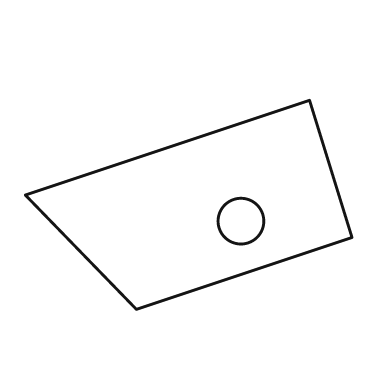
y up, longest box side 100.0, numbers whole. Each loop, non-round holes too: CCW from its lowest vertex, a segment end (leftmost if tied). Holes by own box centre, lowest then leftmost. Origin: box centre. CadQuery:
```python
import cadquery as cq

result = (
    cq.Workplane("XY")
    .moveTo(-16.0, -32.0)
    .lineTo(50.0, -10.0)
    .lineTo(37.0, 32.0)
    .lineTo(-50.0, 3.0)
    .close()
    .moveTo(16.0, -5.0)
    .circle(7.0)
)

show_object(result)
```